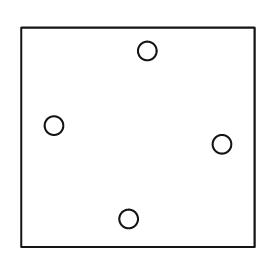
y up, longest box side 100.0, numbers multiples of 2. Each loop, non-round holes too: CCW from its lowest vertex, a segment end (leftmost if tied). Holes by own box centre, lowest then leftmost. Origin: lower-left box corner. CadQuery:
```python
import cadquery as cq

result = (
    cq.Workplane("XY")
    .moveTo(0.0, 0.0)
    .lineTo(100.0, 0.0)
    .lineTo(100.0, 94.0)
    .lineTo(0.0, 94.0)
    .close()
    .moveTo(46.0, 12.0)
    .circle(4.0)
    .moveTo(86.0, 44.0)
    .circle(4.0)
    .moveTo(14.0, 52.0)
    .circle(4.0)
    .moveTo(54.0, 84.0)
    .circle(4.0)
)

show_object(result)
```